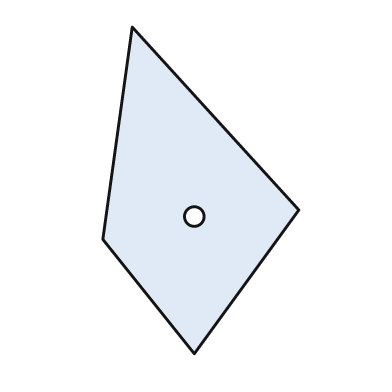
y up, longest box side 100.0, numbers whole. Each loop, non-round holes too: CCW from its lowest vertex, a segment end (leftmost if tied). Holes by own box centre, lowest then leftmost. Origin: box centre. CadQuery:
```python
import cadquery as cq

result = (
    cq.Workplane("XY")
    .moveTo(-2.0, -50.0)
    .lineTo(30.0, -6.0)
    .lineTo(-21.0, 50.0)
    .lineTo(-30.0, -15.0)
    .close()
    .moveTo(-2.0, -8.0)
    .circle(3.0)
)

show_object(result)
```